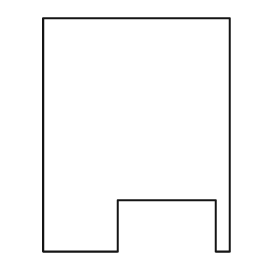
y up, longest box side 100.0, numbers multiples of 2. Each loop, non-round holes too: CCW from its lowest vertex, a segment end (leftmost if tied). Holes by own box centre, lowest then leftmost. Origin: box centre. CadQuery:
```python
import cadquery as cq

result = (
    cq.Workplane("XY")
    .moveTo(-40.0, -50.0)
    .lineTo(-8.0, -50.0)
    .lineTo(-8.0, -28.0)
    .lineTo(34.0, -28.0)
    .lineTo(34.0, -50.0)
    .lineTo(40.0, -50.0)
    .lineTo(40.0, 50.0)
    .lineTo(-40.0, 50.0)
    .close()
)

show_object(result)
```